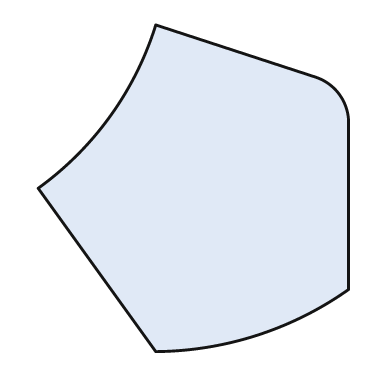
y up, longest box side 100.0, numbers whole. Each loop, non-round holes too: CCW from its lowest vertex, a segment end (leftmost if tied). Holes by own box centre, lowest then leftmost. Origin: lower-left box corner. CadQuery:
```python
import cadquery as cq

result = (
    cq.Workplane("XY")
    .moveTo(36.0, 0.0)
    .threePointArc((67.0, 5.0), (95.0, 19.0))
    .lineTo(95.0, 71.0)
    .threePointArc((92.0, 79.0), (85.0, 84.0))
    .lineTo(36.0, 100.0)
    .threePointArc((22.0, 72.0), (0.0, 50.0))
    .close()
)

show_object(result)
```